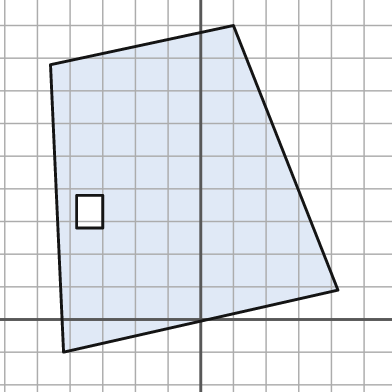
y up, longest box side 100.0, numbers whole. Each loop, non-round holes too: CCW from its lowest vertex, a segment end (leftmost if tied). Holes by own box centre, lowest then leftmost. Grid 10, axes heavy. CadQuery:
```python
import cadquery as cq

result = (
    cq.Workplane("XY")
    .moveTo(-42.0, -10.0)
    .lineTo(42.0, 9.0)
    .lineTo(10.0, 90.0)
    .lineTo(-46.0, 78.0)
    .close()
    .moveTo(-38.0, 28.0)
    .lineTo(-30.0, 28.0)
    .lineTo(-30.0, 38.0)
    .lineTo(-38.0, 38.0)
    .close()
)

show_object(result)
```